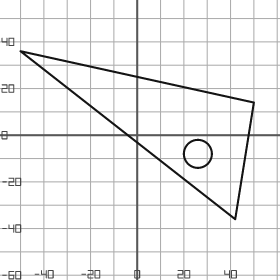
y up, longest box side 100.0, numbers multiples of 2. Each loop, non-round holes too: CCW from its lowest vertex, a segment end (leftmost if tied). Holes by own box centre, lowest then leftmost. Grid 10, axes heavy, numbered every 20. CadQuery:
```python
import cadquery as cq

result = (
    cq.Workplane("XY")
    .moveTo(42.0, -36.0)
    .lineTo(50.0, 14.0)
    .lineTo(-50.0, 36.0)
    .close()
    .moveTo(26.0, -8.0)
    .circle(6.0)
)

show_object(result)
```